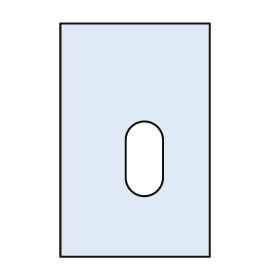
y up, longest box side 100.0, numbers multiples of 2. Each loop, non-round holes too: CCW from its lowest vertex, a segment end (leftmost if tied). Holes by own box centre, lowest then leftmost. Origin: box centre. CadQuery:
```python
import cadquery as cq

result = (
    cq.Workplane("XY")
    .moveTo(-32.0, -50.0)
    .lineTo(32.0, -50.0)
    .lineTo(32.0, 50.0)
    .lineTo(-32.0, 50.0)
    .close()
    .moveTo(-4.0, -16.0)
    .threePointArc((4.0, -24.0), (12.0, -16.0))
    .lineTo(12.0, 0.0)
    .threePointArc((4.0, 8.0), (-4.0, 0.0))
    .close()
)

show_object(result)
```